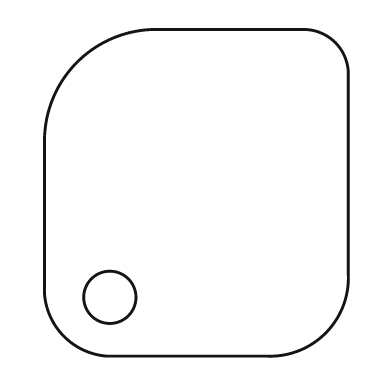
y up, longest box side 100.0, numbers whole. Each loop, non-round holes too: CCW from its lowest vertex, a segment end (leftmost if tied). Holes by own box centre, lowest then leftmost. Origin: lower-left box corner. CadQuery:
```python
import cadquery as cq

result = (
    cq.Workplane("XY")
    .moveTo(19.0, 0.0)
    .lineTo(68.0, 0.0)
    .threePointArc((86.0, 7.0), (93.0, 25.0))
    .lineTo(93.0, 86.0)
    .threePointArc((89.0, 96.0), (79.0, 100.0))
    .lineTo(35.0, 100.0)
    .threePointArc((10.0, 90.0), (0.0, 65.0))
    .lineTo(0.0, 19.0)
    .threePointArc((6.0, 6.0), (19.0, 0.0))
    .close()
    .moveTo(20.0, 18.0)
    .circle(8.0)
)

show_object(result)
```